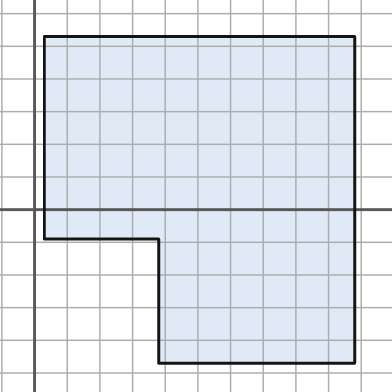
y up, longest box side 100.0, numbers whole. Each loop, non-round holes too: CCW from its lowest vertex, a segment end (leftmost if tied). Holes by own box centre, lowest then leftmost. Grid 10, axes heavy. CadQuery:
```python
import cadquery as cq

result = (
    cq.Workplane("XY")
    .moveTo(38.0, -47.0)
    .lineTo(98.0, -47.0)
    .lineTo(98.0, 53.0)
    .lineTo(3.0, 53.0)
    .lineTo(3.0, -9.0)
    .lineTo(38.0, -9.0)
    .close()
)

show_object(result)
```